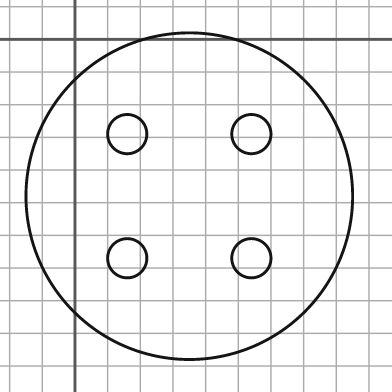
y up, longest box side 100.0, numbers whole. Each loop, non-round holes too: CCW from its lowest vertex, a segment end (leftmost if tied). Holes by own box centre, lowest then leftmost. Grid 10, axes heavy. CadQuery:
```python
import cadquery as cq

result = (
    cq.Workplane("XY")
    .moveTo(35.0, -48.0)
    .circle(50.0)
    .moveTo(16.0, -67.0)
    .circle(6.0)
    .moveTo(54.0, -67.0)
    .circle(6.0)
    .moveTo(16.0, -29.0)
    .circle(6.0)
    .moveTo(54.0, -29.0)
    .circle(6.0)
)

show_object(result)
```